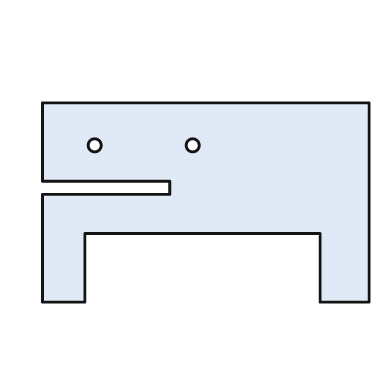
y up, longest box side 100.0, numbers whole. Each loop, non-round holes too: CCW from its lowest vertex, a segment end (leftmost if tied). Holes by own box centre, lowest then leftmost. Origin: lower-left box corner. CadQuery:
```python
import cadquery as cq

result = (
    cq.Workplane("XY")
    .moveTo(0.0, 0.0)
    .lineTo(13.0, 0.0)
    .lineTo(13.0, 21.0)
    .lineTo(85.0, 21.0)
    .lineTo(85.0, 0.0)
    .lineTo(100.0, 0.0)
    .lineTo(100.0, 61.0)
    .lineTo(0.0, 61.0)
    .lineTo(0.0, 37.0)
    .lineTo(39.0, 37.0)
    .lineTo(39.0, 33.0)
    .lineTo(0.0, 33.0)
    .close()
    .moveTo(16.0, 48.0)
    .circle(2.0)
    .moveTo(46.0, 48.0)
    .circle(2.0)
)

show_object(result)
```